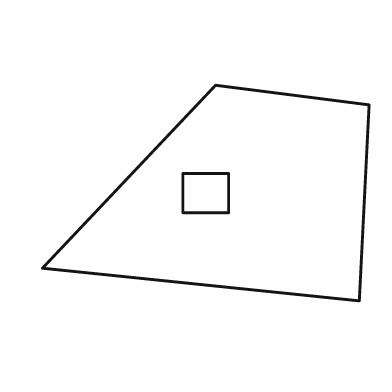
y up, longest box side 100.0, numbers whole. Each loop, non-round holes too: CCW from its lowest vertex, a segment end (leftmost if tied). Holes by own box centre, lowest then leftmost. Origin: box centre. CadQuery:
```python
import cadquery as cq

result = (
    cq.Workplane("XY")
    .moveTo(47.0, -33.0)
    .lineTo(50.0, 27.0)
    .lineTo(3.0, 33.0)
    .lineTo(-50.0, -23.0)
    .close()
    .moveTo(-7.0, -6.0)
    .lineTo(7.0, -6.0)
    .lineTo(7.0, 6.0)
    .lineTo(-7.0, 6.0)
    .close()
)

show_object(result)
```